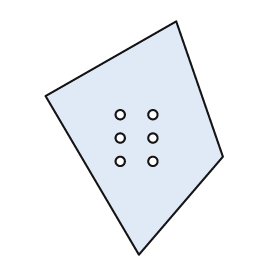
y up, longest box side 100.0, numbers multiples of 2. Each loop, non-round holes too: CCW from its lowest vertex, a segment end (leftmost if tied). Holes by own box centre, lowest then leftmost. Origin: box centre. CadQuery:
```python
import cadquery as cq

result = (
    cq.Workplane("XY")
    .moveTo(2.0, -50.0)
    .lineTo(38.0, -8.0)
    .lineTo(18.0, 50.0)
    .lineTo(-38.0, 18.0)
    .close()
    .moveTo(-6.0, -10.0)
    .circle(2.0)
    .moveTo(8.0, -10.0)
    .circle(2.0)
    .moveTo(-6.0, 0.0)
    .circle(2.0)
    .moveTo(8.0, 0.0)
    .circle(2.0)
    .moveTo(-6.0, 10.0)
    .circle(2.0)
    .moveTo(8.0, 10.0)
    .circle(2.0)
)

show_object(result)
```